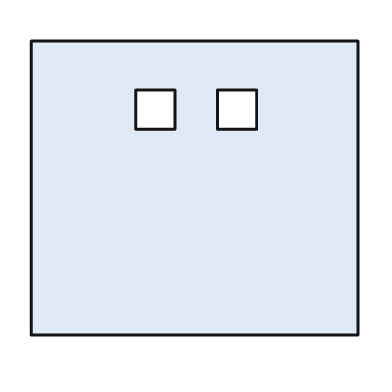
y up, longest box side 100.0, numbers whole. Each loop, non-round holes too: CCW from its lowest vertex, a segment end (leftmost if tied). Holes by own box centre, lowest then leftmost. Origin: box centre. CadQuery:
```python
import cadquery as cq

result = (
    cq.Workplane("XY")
    .moveTo(-50.0, -45.0)
    .lineTo(50.0, -45.0)
    .lineTo(50.0, 45.0)
    .lineTo(-50.0, 45.0)
    .close()
    .moveTo(-18.0, 18.0)
    .lineTo(-6.0, 18.0)
    .lineTo(-6.0, 30.0)
    .lineTo(-18.0, 30.0)
    .close()
    .moveTo(7.0, 18.0)
    .lineTo(19.0, 18.0)
    .lineTo(19.0, 30.0)
    .lineTo(7.0, 30.0)
    .close()
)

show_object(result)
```